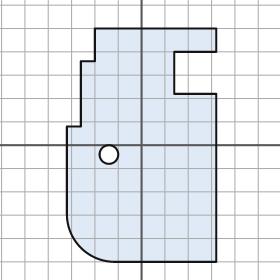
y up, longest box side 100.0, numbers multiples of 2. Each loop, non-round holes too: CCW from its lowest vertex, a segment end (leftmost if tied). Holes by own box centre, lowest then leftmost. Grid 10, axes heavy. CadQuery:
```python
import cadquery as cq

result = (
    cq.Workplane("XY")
    .moveTo(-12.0, -50.0)
    .lineTo(32.0, -50.0)
    .lineTo(32.0, 22.0)
    .lineTo(14.0, 22.0)
    .lineTo(14.0, 40.0)
    .lineTo(32.0, 40.0)
    .lineTo(32.0, 50.0)
    .lineTo(-20.0, 50.0)
    .lineTo(-20.0, 36.0)
    .lineTo(-26.0, 36.0)
    .lineTo(-26.0, 8.0)
    .lineTo(-32.0, 8.0)
    .lineTo(-32.0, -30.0)
    .threePointArc((-26.0, -44.0), (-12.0, -50.0))
    .close()
    .moveTo(-14.0, -4.0)
    .circle(4.0)
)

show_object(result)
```